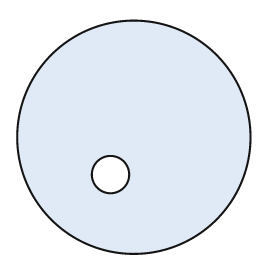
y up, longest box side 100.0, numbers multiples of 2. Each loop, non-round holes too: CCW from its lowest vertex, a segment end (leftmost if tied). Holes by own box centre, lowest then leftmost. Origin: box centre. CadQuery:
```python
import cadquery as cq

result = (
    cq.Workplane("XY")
    .moveTo(0.0, 0.0)
    .circle(50.0)
    .moveTo(-10.0, -16.0)
    .circle(8.0)
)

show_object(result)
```